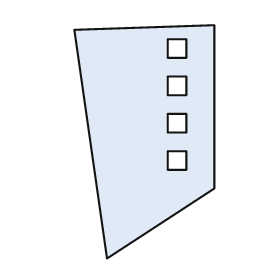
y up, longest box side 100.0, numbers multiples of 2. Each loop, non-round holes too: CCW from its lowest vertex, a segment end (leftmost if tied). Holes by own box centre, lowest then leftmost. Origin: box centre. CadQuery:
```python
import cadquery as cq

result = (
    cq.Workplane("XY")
    .moveTo(-16.0, -50.0)
    .lineTo(30.0, -20.0)
    .lineTo(30.0, 50.0)
    .lineTo(-30.0, 48.0)
    .close()
    .moveTo(10.0, -12.0)
    .lineTo(18.0, -12.0)
    .lineTo(18.0, -4.0)
    .lineTo(10.0, -4.0)
    .close()
    .moveTo(10.0, 4.0)
    .lineTo(18.0, 4.0)
    .lineTo(18.0, 12.0)
    .lineTo(10.0, 12.0)
    .close()
    .moveTo(10.0, 20.0)
    .lineTo(18.0, 20.0)
    .lineTo(18.0, 28.0)
    .lineTo(10.0, 28.0)
    .close()
    .moveTo(10.0, 36.0)
    .lineTo(18.0, 36.0)
    .lineTo(18.0, 44.0)
    .lineTo(10.0, 44.0)
    .close()
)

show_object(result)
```